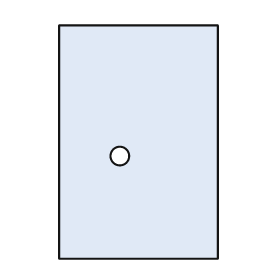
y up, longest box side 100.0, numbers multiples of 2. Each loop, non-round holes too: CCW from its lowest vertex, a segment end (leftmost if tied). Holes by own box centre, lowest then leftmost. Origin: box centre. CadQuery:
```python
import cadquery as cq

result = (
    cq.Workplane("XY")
    .moveTo(-34.0, -50.0)
    .lineTo(34.0, -50.0)
    .lineTo(34.0, 50.0)
    .lineTo(-34.0, 50.0)
    .close()
    .moveTo(-8.0, -6.0)
    .circle(4.0)
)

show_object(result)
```